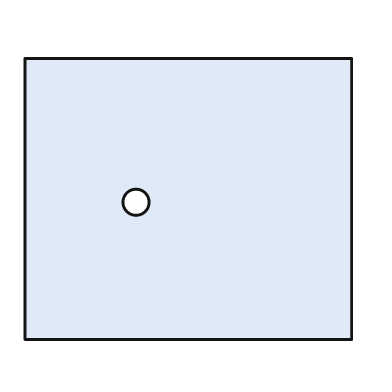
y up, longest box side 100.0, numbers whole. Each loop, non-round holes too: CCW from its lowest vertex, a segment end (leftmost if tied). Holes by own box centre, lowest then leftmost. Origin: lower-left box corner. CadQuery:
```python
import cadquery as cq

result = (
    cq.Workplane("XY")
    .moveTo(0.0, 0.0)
    .lineTo(100.0, 0.0)
    .lineTo(100.0, 86.0)
    .lineTo(0.0, 86.0)
    .close()
    .moveTo(34.0, 42.0)
    .circle(4.0)
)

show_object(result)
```